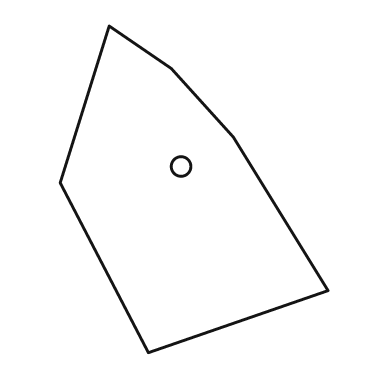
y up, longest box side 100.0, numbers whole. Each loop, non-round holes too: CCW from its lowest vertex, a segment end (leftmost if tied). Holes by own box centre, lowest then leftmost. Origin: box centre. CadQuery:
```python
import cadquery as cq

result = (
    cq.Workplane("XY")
    .moveTo(-14.0, -50.0)
    .lineTo(41.0, -31.0)
    .lineTo(12.0, 16.0)
    .lineTo(-7.0, 37.0)
    .lineTo(-26.0, 50.0)
    .lineTo(-41.0, 2.0)
    .close()
    .moveTo(-4.0, 7.0)
    .circle(3.0)
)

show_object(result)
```